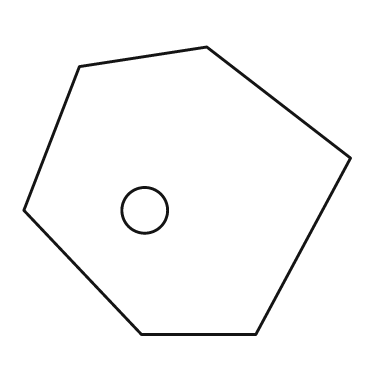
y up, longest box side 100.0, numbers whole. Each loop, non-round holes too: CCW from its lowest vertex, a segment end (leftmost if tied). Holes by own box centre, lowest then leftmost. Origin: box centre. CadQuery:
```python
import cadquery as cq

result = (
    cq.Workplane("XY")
    .moveTo(-14.0, -44.0)
    .lineTo(21.0, -44.0)
    .lineTo(50.0, 10.0)
    .lineTo(6.0, 44.0)
    .lineTo(-33.0, 38.0)
    .lineTo(-50.0, -6.0)
    .close()
    .moveTo(-13.0, -6.0)
    .circle(7.0)
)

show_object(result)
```